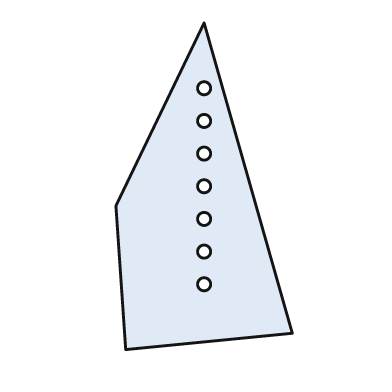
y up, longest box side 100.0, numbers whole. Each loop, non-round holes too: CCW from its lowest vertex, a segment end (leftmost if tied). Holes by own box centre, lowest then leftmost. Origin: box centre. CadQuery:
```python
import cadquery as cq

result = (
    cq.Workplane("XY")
    .moveTo(-24.0, -50.0)
    .lineTo(27.0, -45.0)
    .lineTo(0.0, 50.0)
    .lineTo(-27.0, -6.0)
    .close()
    .moveTo(0.0, -30.0)
    .circle(2.0)
    .moveTo(0.0, -20.0)
    .circle(2.0)
    .moveTo(0.0, -10.0)
    .circle(2.0)
    .moveTo(0.0, 0.0)
    .circle(2.0)
    .moveTo(0.0, 10.0)
    .circle(2.0)
    .moveTo(0.0, 20.0)
    .circle(2.0)
    .moveTo(0.0, 30.0)
    .circle(2.0)
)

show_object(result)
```